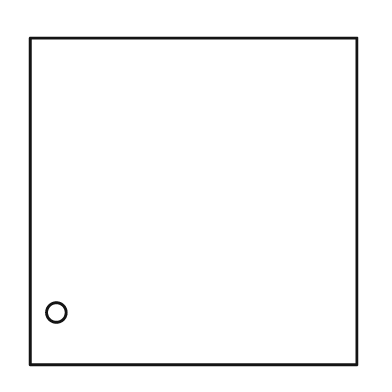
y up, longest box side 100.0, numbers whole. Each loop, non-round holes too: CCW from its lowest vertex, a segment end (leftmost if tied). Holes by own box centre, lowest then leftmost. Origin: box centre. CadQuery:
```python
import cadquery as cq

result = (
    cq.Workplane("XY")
    .moveTo(-50.0, -50.0)
    .lineTo(50.0, -50.0)
    .lineTo(50.0, 50.0)
    .lineTo(-50.0, 50.0)
    .close()
    .moveTo(-42.0, -34.0)
    .circle(3.0)
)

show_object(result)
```